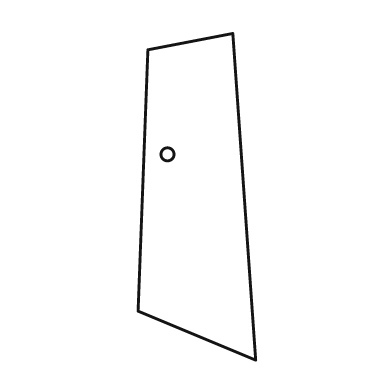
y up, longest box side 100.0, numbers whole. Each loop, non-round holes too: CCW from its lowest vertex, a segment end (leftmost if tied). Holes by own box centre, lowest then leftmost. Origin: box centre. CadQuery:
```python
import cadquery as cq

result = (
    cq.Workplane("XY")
    .moveTo(18.0, -50.0)
    .lineTo(11.0, 50.0)
    .lineTo(-15.0, 45.0)
    .lineTo(-18.0, -35.0)
    .close()
    .moveTo(-9.0, 13.0)
    .circle(2.0)
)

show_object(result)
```